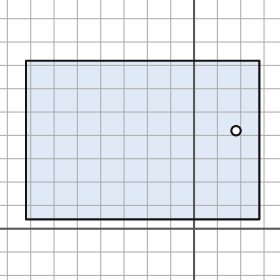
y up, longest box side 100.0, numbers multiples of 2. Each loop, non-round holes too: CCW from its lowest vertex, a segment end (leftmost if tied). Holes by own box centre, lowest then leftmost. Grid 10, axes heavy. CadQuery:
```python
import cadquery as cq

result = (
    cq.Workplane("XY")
    .moveTo(-72.0, 4.0)
    .lineTo(28.0, 4.0)
    .lineTo(28.0, 72.0)
    .lineTo(-72.0, 72.0)
    .close()
    .moveTo(18.0, 42.0)
    .circle(2.0)
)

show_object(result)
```